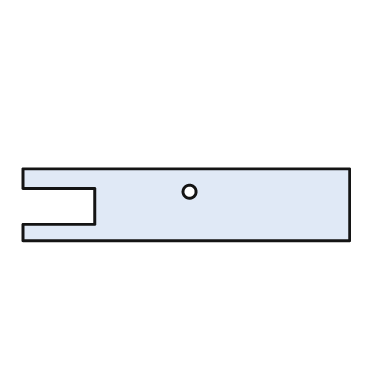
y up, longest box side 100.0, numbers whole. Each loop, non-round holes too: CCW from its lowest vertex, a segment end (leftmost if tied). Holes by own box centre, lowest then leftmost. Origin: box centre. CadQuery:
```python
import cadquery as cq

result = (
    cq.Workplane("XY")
    .moveTo(-50.0, -11.0)
    .lineTo(50.0, -11.0)
    .lineTo(50.0, 11.0)
    .lineTo(-50.0, 11.0)
    .lineTo(-50.0, 5.0)
    .lineTo(-28.0, 5.0)
    .lineTo(-28.0, -6.0)
    .lineTo(-50.0, -6.0)
    .close()
    .moveTo(1.0, 4.0)
    .circle(2.0)
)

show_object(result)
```